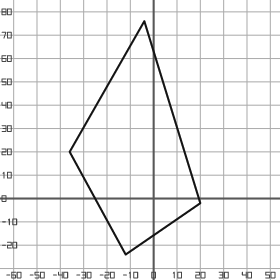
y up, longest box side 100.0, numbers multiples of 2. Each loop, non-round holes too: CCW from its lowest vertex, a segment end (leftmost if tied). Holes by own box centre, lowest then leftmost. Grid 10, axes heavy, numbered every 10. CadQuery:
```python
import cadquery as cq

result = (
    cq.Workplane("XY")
    .moveTo(-12.0, -24.0)
    .lineTo(20.0, -2.0)
    .lineTo(-4.0, 76.0)
    .lineTo(-36.0, 20.0)
    .close()
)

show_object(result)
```